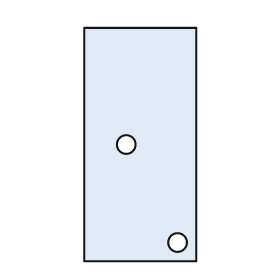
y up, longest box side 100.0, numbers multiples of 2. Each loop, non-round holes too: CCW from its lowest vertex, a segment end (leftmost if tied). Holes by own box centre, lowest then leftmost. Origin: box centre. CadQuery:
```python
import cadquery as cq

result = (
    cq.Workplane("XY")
    .moveTo(-24.0, -50.0)
    .lineTo(24.0, -50.0)
    .lineTo(24.0, 50.0)
    .lineTo(-24.0, 50.0)
    .close()
    .moveTo(16.0, -42.0)
    .circle(4.0)
    .moveTo(-6.0, 0.0)
    .circle(4.0)
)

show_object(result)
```